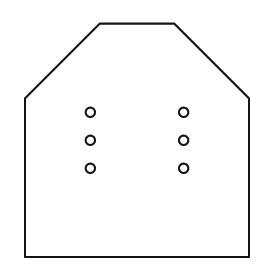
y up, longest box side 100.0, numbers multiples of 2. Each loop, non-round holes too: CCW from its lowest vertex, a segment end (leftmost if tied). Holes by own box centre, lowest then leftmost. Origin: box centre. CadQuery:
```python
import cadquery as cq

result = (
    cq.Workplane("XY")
    .moveTo(-48.0, -50.0)
    .lineTo(48.0, -50.0)
    .lineTo(48.0, 18.0)
    .lineTo(16.0, 50.0)
    .lineTo(-16.0, 50.0)
    .lineTo(-48.0, 18.0)
    .close()
    .moveTo(-20.0, -12.0)
    .circle(2.0)
    .moveTo(20.0, -12.0)
    .circle(2.0)
    .moveTo(-20.0, 0.0)
    .circle(2.0)
    .moveTo(20.0, 0.0)
    .circle(2.0)
    .moveTo(-20.0, 12.0)
    .circle(2.0)
    .moveTo(20.0, 12.0)
    .circle(2.0)
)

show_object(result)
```